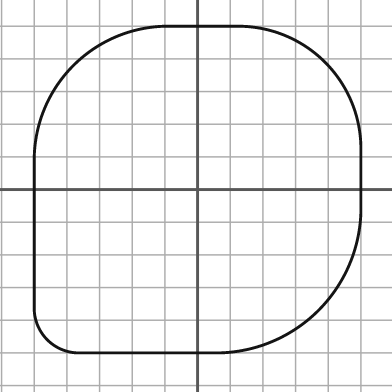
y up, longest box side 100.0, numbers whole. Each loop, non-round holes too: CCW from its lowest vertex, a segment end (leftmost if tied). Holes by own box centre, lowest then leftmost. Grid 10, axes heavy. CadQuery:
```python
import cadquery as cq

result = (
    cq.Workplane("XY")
    .moveTo(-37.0, -50.0)
    .lineTo(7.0, -50.0)
    .threePointArc((37.0, -37.0), (50.0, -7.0))
    .lineTo(50.0, 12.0)
    .threePointArc((39.0, 39.0), (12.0, 50.0))
    .lineTo(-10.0, 50.0)
    .threePointArc((-38.0, 38.0), (-50.0, 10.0))
    .lineTo(-50.0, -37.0)
    .threePointArc((-46.0, -46.0), (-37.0, -50.0))
    .close()
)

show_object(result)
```